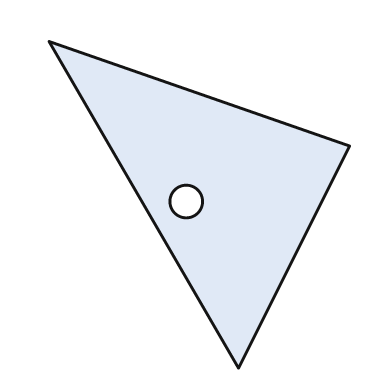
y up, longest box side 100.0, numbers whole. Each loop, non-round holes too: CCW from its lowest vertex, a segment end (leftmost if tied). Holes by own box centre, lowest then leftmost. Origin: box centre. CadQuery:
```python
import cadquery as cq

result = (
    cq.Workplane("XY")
    .moveTo(12.0, -50.0)
    .lineTo(46.0, 18.0)
    .lineTo(-46.0, 50.0)
    .close()
    .moveTo(-4.0, 1.0)
    .circle(5.0)
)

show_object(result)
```